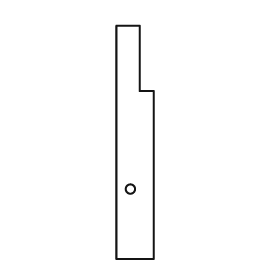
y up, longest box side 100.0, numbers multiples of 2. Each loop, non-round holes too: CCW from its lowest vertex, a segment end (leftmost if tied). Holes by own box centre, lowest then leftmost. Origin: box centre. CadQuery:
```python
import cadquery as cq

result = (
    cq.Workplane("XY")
    .moveTo(-8.0, -50.0)
    .lineTo(8.0, -50.0)
    .lineTo(8.0, 22.0)
    .lineTo(2.0, 22.0)
    .lineTo(2.0, 50.0)
    .lineTo(-8.0, 50.0)
    .close()
    .moveTo(-2.0, -20.0)
    .circle(2.0)
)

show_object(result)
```